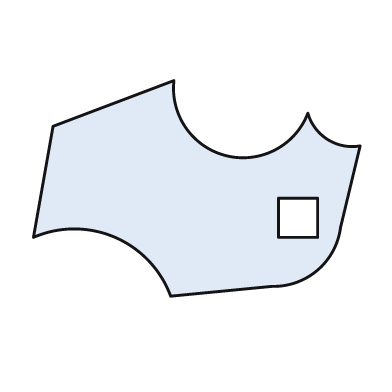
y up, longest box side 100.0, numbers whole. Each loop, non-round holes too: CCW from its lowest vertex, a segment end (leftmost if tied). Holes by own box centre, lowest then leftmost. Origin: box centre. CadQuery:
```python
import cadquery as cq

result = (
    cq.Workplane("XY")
    .moveTo(-8.0, -33.0)
    .lineTo(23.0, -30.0)
    .threePointArc((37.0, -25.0), (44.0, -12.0))
    .lineTo(50.0, 13.0)
    .threePointArc((40.0, 15.0), (34.0, 23.0))
    .threePointArc((9.0, 10.0), (-7.0, 33.0))
    .lineTo(-44.0, 19.0)
    .lineTo(-50.0, -15.0)
    .threePointArc((-25.0, -15.0), (-8.0, -33.0))
    .close()
    .moveTo(25.0, -15.0)
    .lineTo(37.0, -15.0)
    .lineTo(37.0, -3.0)
    .lineTo(25.0, -3.0)
    .close()
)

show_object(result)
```